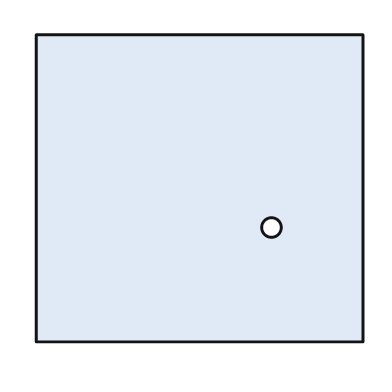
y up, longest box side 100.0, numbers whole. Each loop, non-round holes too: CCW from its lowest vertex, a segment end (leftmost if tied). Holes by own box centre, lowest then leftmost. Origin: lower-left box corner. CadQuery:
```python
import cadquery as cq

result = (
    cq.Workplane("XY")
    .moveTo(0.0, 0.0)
    .lineTo(100.0, 0.0)
    .lineTo(100.0, 94.0)
    .lineTo(0.0, 94.0)
    .close()
    .moveTo(72.0, 35.0)
    .circle(3.0)
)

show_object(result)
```